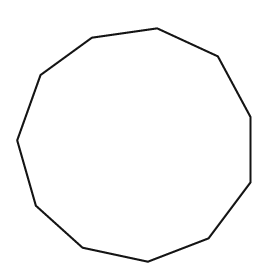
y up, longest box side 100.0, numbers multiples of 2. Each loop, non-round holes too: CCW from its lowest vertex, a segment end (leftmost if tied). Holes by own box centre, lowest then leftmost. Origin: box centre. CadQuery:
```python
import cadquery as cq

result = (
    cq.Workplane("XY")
    .moveTo(6.0, -50.0)
    .lineTo(32.0, -40.0)
    .lineTo(50.0, -16.0)
    .lineTo(50.0, 12.0)
    .lineTo(36.0, 38.0)
    .lineTo(10.0, 50.0)
    .lineTo(-18.0, 46.0)
    .lineTo(-40.0, 30.0)
    .lineTo(-50.0, 2.0)
    .lineTo(-42.0, -26.0)
    .lineTo(-22.0, -44.0)
    .close()
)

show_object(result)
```